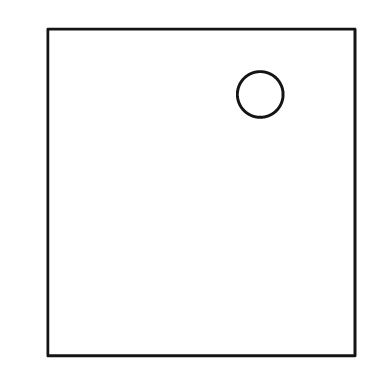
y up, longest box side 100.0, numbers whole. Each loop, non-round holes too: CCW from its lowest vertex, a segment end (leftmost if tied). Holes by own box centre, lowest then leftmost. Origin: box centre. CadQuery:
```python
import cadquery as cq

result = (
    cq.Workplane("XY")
    .moveTo(-47.0, -50.0)
    .lineTo(47.0, -50.0)
    .lineTo(47.0, 50.0)
    .lineTo(-47.0, 50.0)
    .close()
    .moveTo(18.0, 30.0)
    .circle(7.0)
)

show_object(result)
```